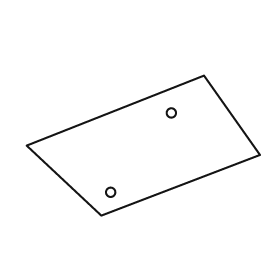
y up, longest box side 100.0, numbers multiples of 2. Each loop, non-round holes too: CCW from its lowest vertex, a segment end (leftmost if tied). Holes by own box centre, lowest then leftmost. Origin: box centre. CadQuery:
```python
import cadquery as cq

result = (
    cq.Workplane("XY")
    .moveTo(-18.0, -30.0)
    .lineTo(50.0, -4.0)
    .lineTo(26.0, 30.0)
    .lineTo(-50.0, 0.0)
    .close()
    .moveTo(-14.0, -20.0)
    .circle(2.0)
    .moveTo(12.0, 14.0)
    .circle(2.0)
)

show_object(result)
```